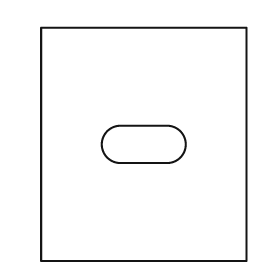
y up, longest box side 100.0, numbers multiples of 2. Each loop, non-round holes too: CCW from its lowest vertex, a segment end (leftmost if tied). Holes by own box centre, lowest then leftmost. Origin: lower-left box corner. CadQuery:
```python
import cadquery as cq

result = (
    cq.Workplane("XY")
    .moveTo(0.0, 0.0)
    .lineTo(88.0, 0.0)
    .lineTo(88.0, 100.0)
    .lineTo(0.0, 100.0)
    .close()
    .moveTo(34.0, 42.0)
    .lineTo(54.0, 42.0)
    .threePointArc((62.0, 50.0), (54.0, 58.0))
    .lineTo(34.0, 58.0)
    .threePointArc((26.0, 50.0), (34.0, 42.0))
    .close()
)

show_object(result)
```